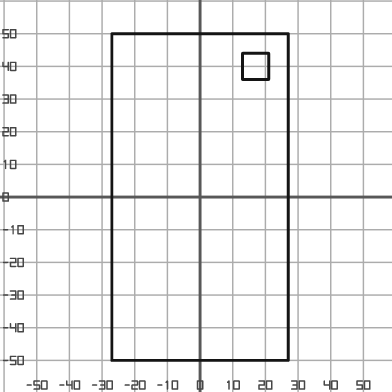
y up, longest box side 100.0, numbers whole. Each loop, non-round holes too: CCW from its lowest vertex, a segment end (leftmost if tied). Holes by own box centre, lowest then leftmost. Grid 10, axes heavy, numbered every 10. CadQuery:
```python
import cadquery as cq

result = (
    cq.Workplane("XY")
    .moveTo(-27.0, -50.0)
    .lineTo(27.0, -50.0)
    .lineTo(27.0, 50.0)
    .lineTo(-27.0, 50.0)
    .close()
    .moveTo(13.0, 36.0)
    .lineTo(21.0, 36.0)
    .lineTo(21.0, 44.0)
    .lineTo(13.0, 44.0)
    .close()
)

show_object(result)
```